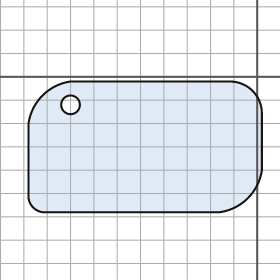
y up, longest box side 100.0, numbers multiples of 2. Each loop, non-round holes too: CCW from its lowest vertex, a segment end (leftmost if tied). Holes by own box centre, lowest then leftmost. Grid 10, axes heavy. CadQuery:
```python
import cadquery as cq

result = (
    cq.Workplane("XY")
    .moveTo(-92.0, -58.0)
    .lineTo(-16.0, -58.0)
    .threePointArc((-4.0, -52.0), (2.0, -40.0))
    .lineTo(2.0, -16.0)
    .threePointArc((-2.0, -6.0), (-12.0, -2.0))
    .lineTo(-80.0, -2.0)
    .threePointArc((-92.0, -8.0), (-98.0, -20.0))
    .lineTo(-98.0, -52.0)
    .threePointArc((-96.0, -56.0), (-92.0, -58.0))
    .close()
    .moveTo(-80.0, -12.0)
    .circle(4.0)
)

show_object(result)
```